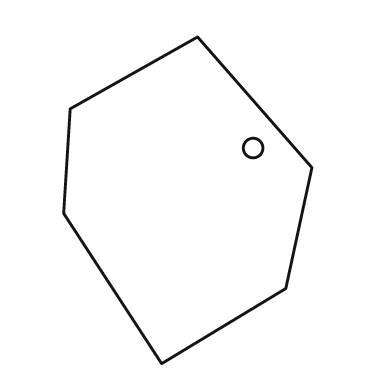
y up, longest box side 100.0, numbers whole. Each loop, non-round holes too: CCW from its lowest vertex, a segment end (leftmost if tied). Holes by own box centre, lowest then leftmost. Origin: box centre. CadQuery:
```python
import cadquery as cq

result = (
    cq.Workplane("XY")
    .moveTo(-8.0, -50.0)
    .lineTo(30.0, -27.0)
    .lineTo(38.0, 10.0)
    .lineTo(3.0, 50.0)
    .lineTo(-36.0, 28.0)
    .lineTo(-38.0, -4.0)
    .close()
    .moveTo(20.0, 16.0)
    .circle(3.0)
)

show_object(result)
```